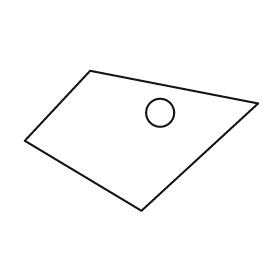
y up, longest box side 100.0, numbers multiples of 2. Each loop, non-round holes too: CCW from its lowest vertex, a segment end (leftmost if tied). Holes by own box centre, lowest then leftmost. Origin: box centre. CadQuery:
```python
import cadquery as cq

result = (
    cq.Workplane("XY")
    .moveTo(0.0, -30.0)
    .lineTo(50.0, 16.0)
    .lineTo(-22.0, 30.0)
    .lineTo(-50.0, 0.0)
    .close()
    .moveTo(8.0, 12.0)
    .circle(6.0)
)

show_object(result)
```